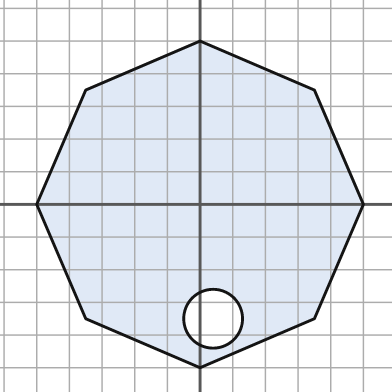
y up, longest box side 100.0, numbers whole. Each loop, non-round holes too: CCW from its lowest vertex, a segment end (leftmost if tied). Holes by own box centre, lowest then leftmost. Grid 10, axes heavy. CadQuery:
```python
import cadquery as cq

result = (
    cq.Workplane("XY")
    .moveTo(0.0, -50.0)
    .lineTo(35.0, -35.0)
    .lineTo(50.0, 0.0)
    .lineTo(35.0, 35.0)
    .lineTo(0.0, 50.0)
    .lineTo(-35.0, 35.0)
    .lineTo(-50.0, 0.0)
    .lineTo(-35.0, -35.0)
    .close()
    .moveTo(4.0, -35.0)
    .circle(9.0)
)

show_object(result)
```